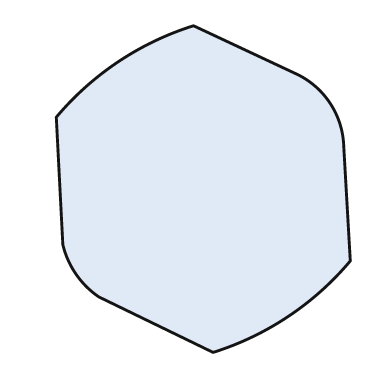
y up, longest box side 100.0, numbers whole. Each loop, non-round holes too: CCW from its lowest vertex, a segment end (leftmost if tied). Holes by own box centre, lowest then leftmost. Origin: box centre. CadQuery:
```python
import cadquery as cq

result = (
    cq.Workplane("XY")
    .moveTo(3.0, -50.0)
    .threePointArc((26.0, -39.0), (45.0, -22.0))
    .lineTo(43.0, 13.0)
    .threePointArc((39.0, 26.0), (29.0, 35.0))
    .lineTo(-3.0, 50.0)
    .threePointArc((-26.0, 39.0), (-45.0, 22.0))
    .lineTo(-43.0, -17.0)
    .threePointArc((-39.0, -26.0), (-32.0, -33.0))
    .close()
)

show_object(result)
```